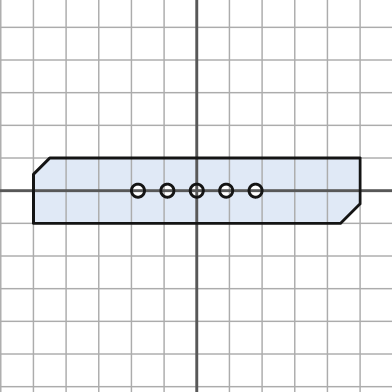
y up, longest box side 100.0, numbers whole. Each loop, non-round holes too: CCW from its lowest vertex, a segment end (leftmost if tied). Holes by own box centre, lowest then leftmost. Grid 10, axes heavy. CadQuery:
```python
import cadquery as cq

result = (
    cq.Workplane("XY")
    .moveTo(-50.0, -10.0)
    .lineTo(44.0, -10.0)
    .lineTo(50.0, -4.0)
    .lineTo(50.0, 10.0)
    .lineTo(-45.0, 10.0)
    .lineTo(-50.0, 5.0)
    .close()
    .moveTo(-18.0, 0.0)
    .circle(2.0)
    .moveTo(-9.0, 0.0)
    .circle(2.0)
    .moveTo(0.0, 0.0)
    .circle(2.0)
    .moveTo(9.0, 0.0)
    .circle(2.0)
    .moveTo(18.0, 0.0)
    .circle(2.0)
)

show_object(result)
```